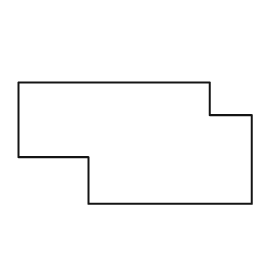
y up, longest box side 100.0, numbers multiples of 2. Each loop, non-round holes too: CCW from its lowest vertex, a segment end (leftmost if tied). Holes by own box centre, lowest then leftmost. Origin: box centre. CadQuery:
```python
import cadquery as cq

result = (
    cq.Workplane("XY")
    .moveTo(-20.0, -26.0)
    .lineTo(50.0, -26.0)
    .lineTo(50.0, 12.0)
    .lineTo(32.0, 12.0)
    .lineTo(32.0, 26.0)
    .lineTo(-50.0, 26.0)
    .lineTo(-50.0, -6.0)
    .lineTo(-20.0, -6.0)
    .close()
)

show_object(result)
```